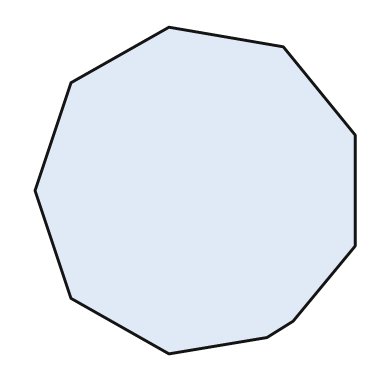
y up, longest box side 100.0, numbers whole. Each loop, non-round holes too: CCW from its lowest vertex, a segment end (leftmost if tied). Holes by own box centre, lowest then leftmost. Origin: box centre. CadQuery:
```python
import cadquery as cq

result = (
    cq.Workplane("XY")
    .moveTo(-8.0, -50.0)
    .lineTo(22.0, -45.0)
    .lineTo(30.0, -40.0)
    .lineTo(49.0, -17.0)
    .lineTo(49.0, 17.0)
    .lineTo(27.0, 44.0)
    .lineTo(-8.0, 50.0)
    .lineTo(-38.0, 33.0)
    .lineTo(-49.0, 0.0)
    .lineTo(-38.0, -33.0)
    .close()
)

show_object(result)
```